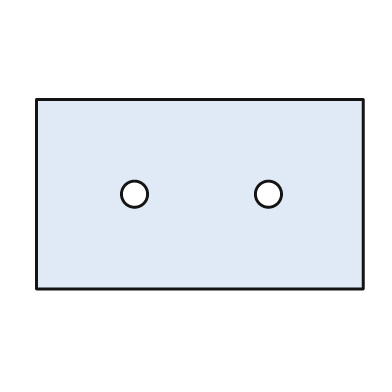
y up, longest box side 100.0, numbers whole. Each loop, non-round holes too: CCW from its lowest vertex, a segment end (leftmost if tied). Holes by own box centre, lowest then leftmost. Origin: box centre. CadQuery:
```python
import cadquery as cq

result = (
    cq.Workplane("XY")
    .moveTo(-50.0, -29.0)
    .lineTo(50.0, -29.0)
    .lineTo(50.0, 29.0)
    .lineTo(-50.0, 29.0)
    .close()
    .moveTo(-20.0, 0.0)
    .circle(4.0)
    .moveTo(21.0, 0.0)
    .circle(4.0)
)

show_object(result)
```